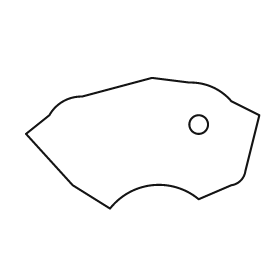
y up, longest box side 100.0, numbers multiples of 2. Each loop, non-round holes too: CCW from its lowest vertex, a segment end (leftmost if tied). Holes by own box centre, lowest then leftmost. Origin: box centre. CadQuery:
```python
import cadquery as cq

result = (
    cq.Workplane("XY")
    .moveTo(-14.0, -28.0)
    .threePointArc((4.0, -18.0), (24.0, -24.0))
    .lineTo(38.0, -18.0)
    .threePointArc((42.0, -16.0), (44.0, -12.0))
    .lineTo(50.0, 12.0)
    .lineTo(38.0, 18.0)
    .threePointArc((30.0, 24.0), (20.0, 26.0))
    .lineTo(4.0, 28.0)
    .lineTo(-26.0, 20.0)
    .threePointArc((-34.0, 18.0), (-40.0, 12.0))
    .lineTo(-50.0, 4.0)
    .lineTo(-30.0, -18.0)
    .close()
    .moveTo(24.0, 8.0)
    .circle(4.0)
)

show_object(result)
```